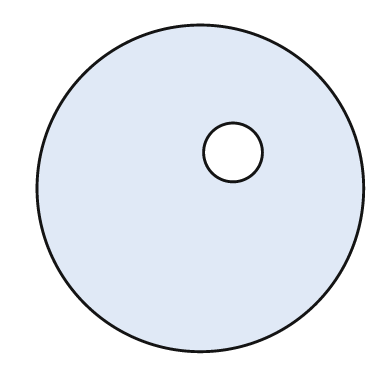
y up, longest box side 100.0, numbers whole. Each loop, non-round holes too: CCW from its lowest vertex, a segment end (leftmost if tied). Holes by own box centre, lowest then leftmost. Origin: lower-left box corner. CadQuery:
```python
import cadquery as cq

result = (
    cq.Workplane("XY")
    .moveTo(50.0, 50.0)
    .circle(50.0)
    .moveTo(60.0, 61.0)
    .circle(9.0)
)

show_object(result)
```